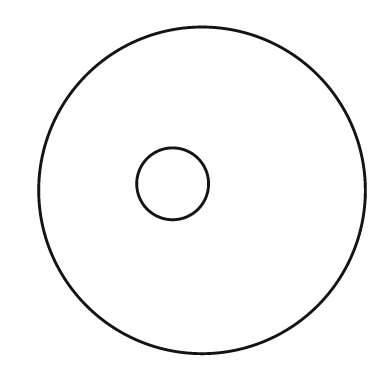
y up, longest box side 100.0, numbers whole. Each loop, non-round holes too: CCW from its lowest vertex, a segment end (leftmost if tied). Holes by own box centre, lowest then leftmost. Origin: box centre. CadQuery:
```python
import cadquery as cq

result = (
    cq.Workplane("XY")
    .moveTo(0.0, 0.0)
    .circle(50.0)
    .moveTo(-9.0, 2.0)
    .circle(11.0)
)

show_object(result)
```